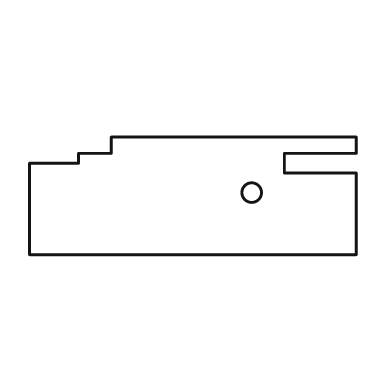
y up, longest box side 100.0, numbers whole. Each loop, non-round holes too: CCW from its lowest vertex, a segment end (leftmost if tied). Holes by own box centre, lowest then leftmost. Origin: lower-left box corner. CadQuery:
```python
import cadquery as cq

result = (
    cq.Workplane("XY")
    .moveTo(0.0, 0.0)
    .lineTo(100.0, 0.0)
    .lineTo(100.0, 25.0)
    .lineTo(78.0, 25.0)
    .lineTo(78.0, 31.0)
    .lineTo(100.0, 31.0)
    .lineTo(100.0, 36.0)
    .lineTo(25.0, 36.0)
    .lineTo(25.0, 31.0)
    .lineTo(15.0, 31.0)
    .lineTo(15.0, 28.0)
    .lineTo(0.0, 28.0)
    .close()
    .moveTo(68.0, 19.0)
    .circle(3.0)
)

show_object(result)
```